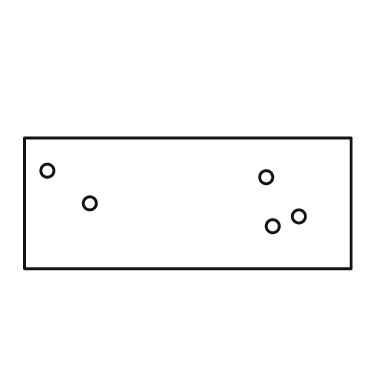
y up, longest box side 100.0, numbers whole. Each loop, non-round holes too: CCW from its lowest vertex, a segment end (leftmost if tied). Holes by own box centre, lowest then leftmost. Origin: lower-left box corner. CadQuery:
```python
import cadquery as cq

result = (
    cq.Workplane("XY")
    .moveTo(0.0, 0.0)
    .lineTo(100.0, 0.0)
    .lineTo(100.0, 40.0)
    .lineTo(0.0, 40.0)
    .close()
    .moveTo(76.0, 13.0)
    .circle(2.0)
    .moveTo(84.0, 16.0)
    .circle(2.0)
    .moveTo(20.0, 20.0)
    .circle(2.0)
    .moveTo(74.0, 28.0)
    .circle(2.0)
    .moveTo(7.0, 30.0)
    .circle(2.0)
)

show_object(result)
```